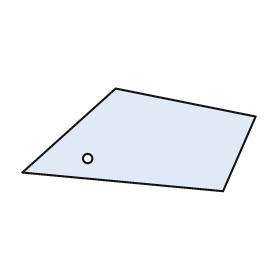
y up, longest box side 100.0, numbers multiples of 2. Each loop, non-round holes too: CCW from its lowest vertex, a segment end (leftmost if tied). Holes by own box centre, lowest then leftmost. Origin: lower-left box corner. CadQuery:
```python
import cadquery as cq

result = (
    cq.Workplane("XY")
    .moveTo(86.0, 0.0)
    .lineTo(100.0, 32.0)
    .lineTo(40.0, 44.0)
    .lineTo(0.0, 8.0)
    .close()
    .moveTo(28.0, 14.0)
    .circle(2.0)
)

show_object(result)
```